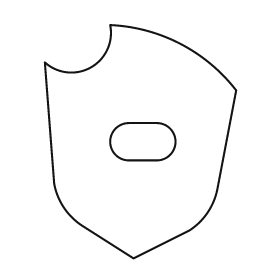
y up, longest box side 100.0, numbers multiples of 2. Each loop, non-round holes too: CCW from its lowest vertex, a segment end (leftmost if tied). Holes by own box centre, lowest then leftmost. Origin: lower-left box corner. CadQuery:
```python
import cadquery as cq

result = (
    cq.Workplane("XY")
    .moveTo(38.0, 0.0)
    .lineTo(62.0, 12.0)
    .threePointArc((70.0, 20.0), (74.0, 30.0))
    .lineTo(82.0, 72.0)
    .threePointArc((58.0, 92.0), (28.0, 100.0))
    .threePointArc((20.0, 82.0), (0.0, 84.0))
    .lineTo(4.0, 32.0)
    .threePointArc((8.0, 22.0), (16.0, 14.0))
    .close()
    .moveTo(36.0, 42.0)
    .lineTo(48.0, 42.0)
    .threePointArc((56.0, 50.0), (48.0, 58.0))
    .lineTo(36.0, 58.0)
    .threePointArc((28.0, 50.0), (36.0, 42.0))
    .close()
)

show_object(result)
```